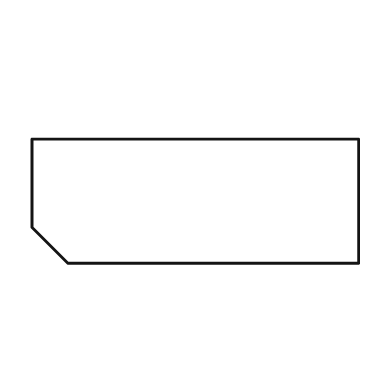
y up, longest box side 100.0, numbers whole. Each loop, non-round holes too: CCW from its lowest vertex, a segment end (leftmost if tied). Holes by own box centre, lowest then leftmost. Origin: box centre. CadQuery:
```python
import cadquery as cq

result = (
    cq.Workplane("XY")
    .moveTo(-39.0, -19.0)
    .lineTo(50.0, -19.0)
    .lineTo(50.0, 19.0)
    .lineTo(-50.0, 19.0)
    .lineTo(-50.0, -8.0)
    .close()
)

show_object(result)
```